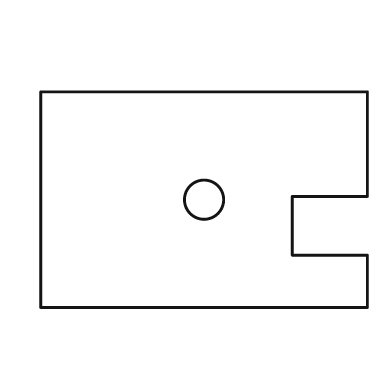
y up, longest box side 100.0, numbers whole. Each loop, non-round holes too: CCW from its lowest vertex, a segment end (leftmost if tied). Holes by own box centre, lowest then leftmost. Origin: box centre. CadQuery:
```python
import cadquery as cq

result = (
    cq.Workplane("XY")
    .moveTo(-50.0, -33.0)
    .lineTo(50.0, -33.0)
    .lineTo(50.0, -17.0)
    .lineTo(27.0, -17.0)
    .lineTo(27.0, 1.0)
    .lineTo(50.0, 1.0)
    .lineTo(50.0, 33.0)
    .lineTo(-50.0, 33.0)
    .close()
    .moveTo(0.0, 0.0)
    .circle(6.0)
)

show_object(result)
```